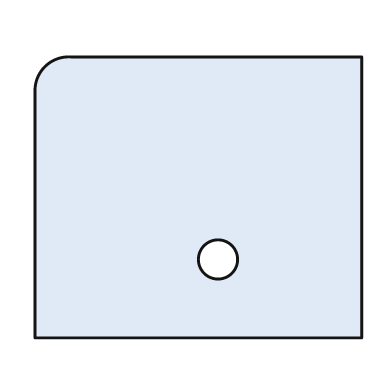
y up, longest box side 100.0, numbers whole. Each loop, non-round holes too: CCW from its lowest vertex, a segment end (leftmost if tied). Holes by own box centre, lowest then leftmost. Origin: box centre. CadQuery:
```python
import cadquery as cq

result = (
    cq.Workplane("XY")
    .moveTo(-50.0, -43.0)
    .lineTo(50.0, -43.0)
    .lineTo(50.0, 43.0)
    .lineTo(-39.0, 43.0)
    .threePointArc((-47.0, 40.0), (-50.0, 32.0))
    .close()
    .moveTo(6.0, -19.0)
    .circle(6.0)
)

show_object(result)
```